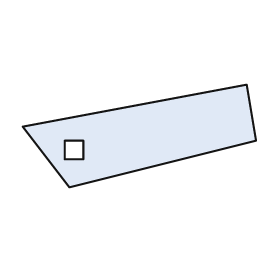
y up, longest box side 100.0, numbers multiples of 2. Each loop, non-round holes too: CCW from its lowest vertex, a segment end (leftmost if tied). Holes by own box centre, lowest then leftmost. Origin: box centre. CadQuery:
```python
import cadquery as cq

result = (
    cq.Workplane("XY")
    .moveTo(-30.0, -22.0)
    .lineTo(50.0, -2.0)
    .lineTo(46.0, 22.0)
    .lineTo(-50.0, 4.0)
    .close()
    .moveTo(-32.0, -10.0)
    .lineTo(-24.0, -10.0)
    .lineTo(-24.0, -2.0)
    .lineTo(-32.0, -2.0)
    .close()
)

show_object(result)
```